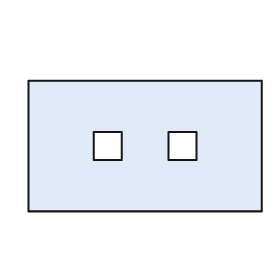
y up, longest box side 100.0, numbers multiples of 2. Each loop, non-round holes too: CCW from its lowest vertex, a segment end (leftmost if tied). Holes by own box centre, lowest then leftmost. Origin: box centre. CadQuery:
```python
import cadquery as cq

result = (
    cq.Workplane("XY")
    .moveTo(-50.0, -28.0)
    .lineTo(50.0, -28.0)
    .lineTo(50.0, 28.0)
    .lineTo(-50.0, 28.0)
    .close()
    .moveTo(-22.0, -6.0)
    .lineTo(-10.0, -6.0)
    .lineTo(-10.0, 6.0)
    .lineTo(-22.0, 6.0)
    .close()
    .moveTo(10.0, -6.0)
    .lineTo(22.0, -6.0)
    .lineTo(22.0, 6.0)
    .lineTo(10.0, 6.0)
    .close()
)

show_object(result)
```